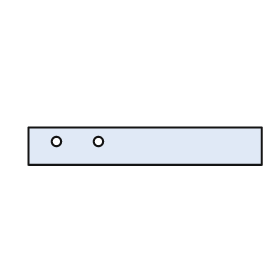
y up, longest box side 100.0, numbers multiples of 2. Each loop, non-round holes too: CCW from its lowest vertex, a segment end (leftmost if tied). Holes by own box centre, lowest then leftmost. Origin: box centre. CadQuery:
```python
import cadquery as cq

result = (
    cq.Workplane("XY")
    .moveTo(-50.0, -8.0)
    .lineTo(50.0, -8.0)
    .lineTo(50.0, 8.0)
    .lineTo(-50.0, 8.0)
    .close()
    .moveTo(-38.0, 2.0)
    .circle(2.0)
    .moveTo(-20.0, 2.0)
    .circle(2.0)
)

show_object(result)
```